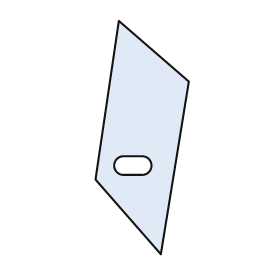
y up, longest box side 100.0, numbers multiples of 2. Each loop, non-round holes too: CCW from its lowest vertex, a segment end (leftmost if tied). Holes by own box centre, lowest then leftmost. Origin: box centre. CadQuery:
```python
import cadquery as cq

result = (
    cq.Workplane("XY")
    .moveTo(8.0, -50.0)
    .lineTo(20.0, 24.0)
    .lineTo(-10.0, 50.0)
    .lineTo(-20.0, -18.0)
    .close()
    .moveTo(-8.0, -16.0)
    .lineTo(0.0, -16.0)
    .threePointArc((4.0, -12.0), (0.0, -8.0))
    .lineTo(-8.0, -8.0)
    .threePointArc((-12.0, -12.0), (-8.0, -16.0))
    .close()
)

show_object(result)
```